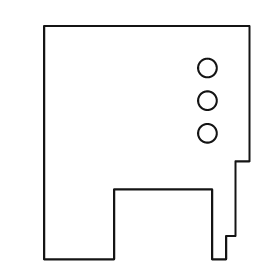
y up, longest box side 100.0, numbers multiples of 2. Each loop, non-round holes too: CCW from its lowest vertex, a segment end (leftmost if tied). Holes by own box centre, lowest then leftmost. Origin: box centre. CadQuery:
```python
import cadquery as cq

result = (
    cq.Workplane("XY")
    .moveTo(-44.0, -50.0)
    .lineTo(-14.0, -50.0)
    .lineTo(-14.0, -20.0)
    .lineTo(28.0, -20.0)
    .lineTo(28.0, -50.0)
    .lineTo(34.0, -50.0)
    .lineTo(34.0, -40.0)
    .lineTo(38.0, -40.0)
    .lineTo(38.0, -8.0)
    .lineTo(44.0, -8.0)
    .lineTo(44.0, 50.0)
    .lineTo(-44.0, 50.0)
    .close()
    .moveTo(26.0, 4.0)
    .circle(4.0)
    .moveTo(26.0, 18.0)
    .circle(4.0)
    .moveTo(26.0, 32.0)
    .circle(4.0)
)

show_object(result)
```